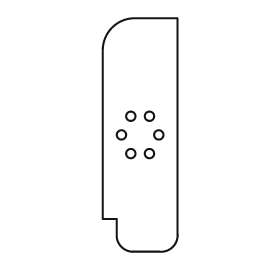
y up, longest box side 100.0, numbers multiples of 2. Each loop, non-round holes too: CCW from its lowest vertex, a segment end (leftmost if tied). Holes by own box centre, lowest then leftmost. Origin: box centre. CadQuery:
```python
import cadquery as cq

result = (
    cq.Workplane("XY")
    .moveTo(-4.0, -50.0)
    .lineTo(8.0, -50.0)
    .threePointArc((14.0, -48.0), (16.0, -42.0))
    .lineTo(16.0, 50.0)
    .lineTo(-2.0, 50.0)
    .threePointArc((-12.0, 46.0), (-16.0, 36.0))
    .lineTo(-16.0, -36.0)
    .lineTo(-10.0, -36.0)
    .lineTo(-10.0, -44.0)
    .threePointArc((-8.0, -48.0), (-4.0, -50.0))
    .close()
    .moveTo(-4.0, -8.0)
    .circle(2.0)
    .moveTo(4.0, -8.0)
    .circle(2.0)
    .moveTo(-8.0, 0.0)
    .circle(2.0)
    .moveTo(8.0, 0.0)
    .circle(2.0)
    .moveTo(-4.0, 8.0)
    .circle(2.0)
    .moveTo(4.0, 8.0)
    .circle(2.0)
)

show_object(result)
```